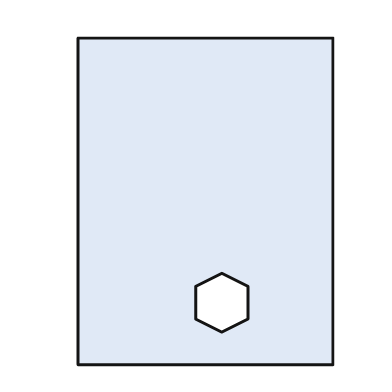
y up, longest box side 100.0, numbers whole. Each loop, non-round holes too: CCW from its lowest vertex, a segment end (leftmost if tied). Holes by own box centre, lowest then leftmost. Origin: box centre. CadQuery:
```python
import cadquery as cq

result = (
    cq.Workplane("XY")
    .moveTo(-39.0, -50.0)
    .lineTo(39.0, -50.0)
    .lineTo(39.0, 50.0)
    .lineTo(-39.0, 50.0)
    .close()
    .moveTo(5.0, -40.0)
    .lineTo(13.0, -36.0)
    .lineTo(13.0, -26.0)
    .lineTo(5.0, -22.0)
    .lineTo(-3.0, -26.0)
    .lineTo(-3.0, -36.0)
    .close()
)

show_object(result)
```